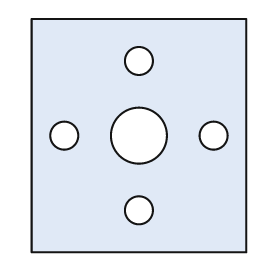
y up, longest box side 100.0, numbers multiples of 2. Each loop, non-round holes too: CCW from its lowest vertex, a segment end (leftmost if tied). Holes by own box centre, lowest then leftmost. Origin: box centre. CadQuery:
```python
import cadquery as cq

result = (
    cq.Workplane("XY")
    .moveTo(-46.0, -50.0)
    .lineTo(46.0, -50.0)
    .lineTo(46.0, 50.0)
    .lineTo(-46.0, 50.0)
    .close()
    .moveTo(0.0, -32.0)
    .circle(6.0)
    .moveTo(-32.0, 0.0)
    .circle(6.0)
    .moveTo(0.0, 0.0)
    .circle(12.0)
    .moveTo(32.0, 0.0)
    .circle(6.0)
    .moveTo(0.0, 32.0)
    .circle(6.0)
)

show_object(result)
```